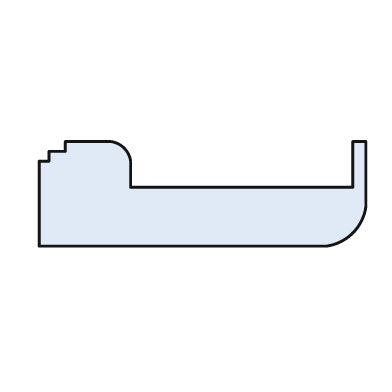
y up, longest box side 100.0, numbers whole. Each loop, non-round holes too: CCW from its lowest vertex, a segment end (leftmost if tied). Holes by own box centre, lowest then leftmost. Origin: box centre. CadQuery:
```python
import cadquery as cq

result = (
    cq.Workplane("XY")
    .moveTo(-50.0, -16.0)
    .lineTo(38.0, -16.0)
    .threePointArc((46.0, -12.0), (50.0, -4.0))
    .lineTo(50.0, 16.0)
    .lineTo(46.0, 16.0)
    .lineTo(46.0, 2.0)
    .lineTo(-22.0, 2.0)
    .lineTo(-22.0, 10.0)
    .threePointArc((-24.0, 14.0), (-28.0, 16.0))
    .lineTo(-42.0, 16.0)
    .lineTo(-42.0, 13.0)
    .lineTo(-47.0, 13.0)
    .lineTo(-47.0, 10.0)
    .lineTo(-50.0, 10.0)
    .close()
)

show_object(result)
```